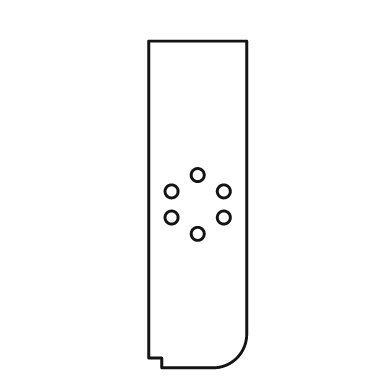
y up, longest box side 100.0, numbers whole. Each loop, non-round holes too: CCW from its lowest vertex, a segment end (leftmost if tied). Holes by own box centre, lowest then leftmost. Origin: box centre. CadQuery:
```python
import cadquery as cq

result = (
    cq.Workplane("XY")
    .moveTo(-11.0, -50.0)
    .lineTo(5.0, -50.0)
    .threePointArc((12.0, -47.0), (15.0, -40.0))
    .lineTo(15.0, 50.0)
    .lineTo(-15.0, 50.0)
    .lineTo(-15.0, -47.0)
    .lineTo(-11.0, -47.0)
    .close()
    .moveTo(0.0, -9.0)
    .circle(2.0)
    .moveTo(-8.0, -4.0)
    .circle(2.0)
    .moveTo(8.0, -4.0)
    .circle(2.0)
    .moveTo(-8.0, 4.0)
    .circle(2.0)
    .moveTo(8.0, 4.0)
    .circle(2.0)
    .moveTo(0.0, 9.0)
    .circle(2.0)
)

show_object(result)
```